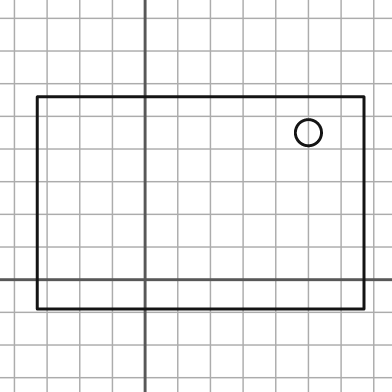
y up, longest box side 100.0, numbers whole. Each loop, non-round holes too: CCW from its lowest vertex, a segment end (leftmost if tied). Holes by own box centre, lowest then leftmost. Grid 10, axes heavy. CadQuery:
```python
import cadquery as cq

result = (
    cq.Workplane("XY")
    .moveTo(-33.0, -9.0)
    .lineTo(67.0, -9.0)
    .lineTo(67.0, 56.0)
    .lineTo(-33.0, 56.0)
    .close()
    .moveTo(50.0, 45.0)
    .circle(4.0)
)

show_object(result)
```